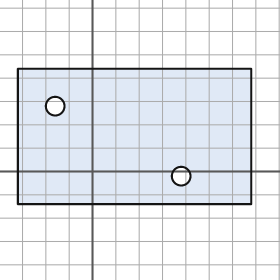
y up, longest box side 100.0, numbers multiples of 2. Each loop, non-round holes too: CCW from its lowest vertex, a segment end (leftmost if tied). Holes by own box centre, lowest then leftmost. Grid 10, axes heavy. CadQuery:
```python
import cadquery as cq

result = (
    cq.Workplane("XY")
    .moveTo(-32.0, -14.0)
    .lineTo(68.0, -14.0)
    .lineTo(68.0, 44.0)
    .lineTo(-32.0, 44.0)
    .close()
    .moveTo(38.0, -2.0)
    .circle(4.0)
    .moveTo(-16.0, 28.0)
    .circle(4.0)
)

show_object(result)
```